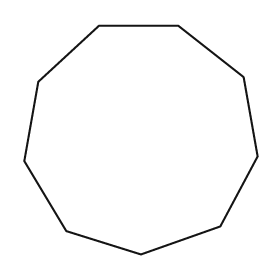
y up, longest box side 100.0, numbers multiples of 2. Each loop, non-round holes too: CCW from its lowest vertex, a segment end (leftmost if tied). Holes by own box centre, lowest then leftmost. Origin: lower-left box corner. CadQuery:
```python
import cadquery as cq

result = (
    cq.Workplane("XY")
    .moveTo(50.0, 0.0)
    .lineTo(84.0, 12.0)
    .lineTo(100.0, 42.0)
    .lineTo(94.0, 76.0)
    .lineTo(66.0, 98.0)
    .lineTo(32.0, 98.0)
    .lineTo(6.0, 74.0)
    .lineTo(0.0, 40.0)
    .lineTo(18.0, 10.0)
    .close()
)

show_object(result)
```